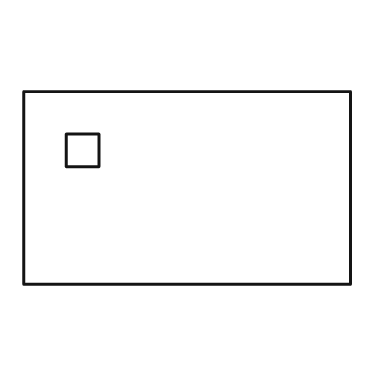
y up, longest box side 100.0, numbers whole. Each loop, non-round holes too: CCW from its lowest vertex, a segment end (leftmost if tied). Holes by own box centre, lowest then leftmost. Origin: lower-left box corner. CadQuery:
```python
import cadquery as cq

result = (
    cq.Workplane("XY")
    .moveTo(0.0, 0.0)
    .lineTo(100.0, 0.0)
    .lineTo(100.0, 59.0)
    .lineTo(0.0, 59.0)
    .close()
    .moveTo(13.0, 36.0)
    .lineTo(23.0, 36.0)
    .lineTo(23.0, 46.0)
    .lineTo(13.0, 46.0)
    .close()
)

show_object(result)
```